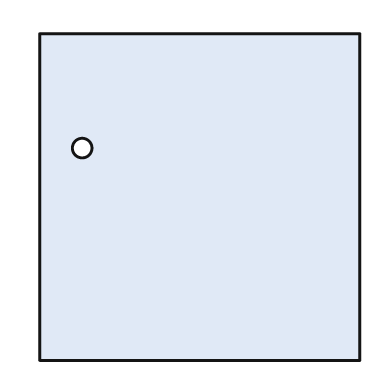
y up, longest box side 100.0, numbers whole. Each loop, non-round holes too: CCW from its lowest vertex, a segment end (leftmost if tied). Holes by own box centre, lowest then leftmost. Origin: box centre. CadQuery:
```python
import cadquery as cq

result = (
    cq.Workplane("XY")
    .moveTo(-49.0, -50.0)
    .lineTo(49.0, -50.0)
    .lineTo(49.0, 50.0)
    .lineTo(-49.0, 50.0)
    .close()
    .moveTo(-36.0, 15.0)
    .circle(3.0)
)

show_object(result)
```